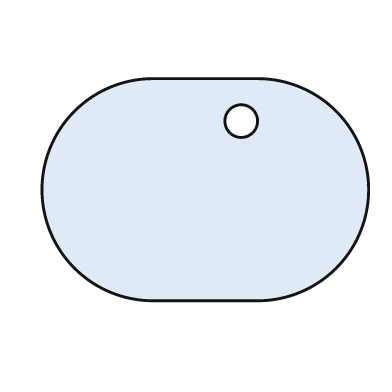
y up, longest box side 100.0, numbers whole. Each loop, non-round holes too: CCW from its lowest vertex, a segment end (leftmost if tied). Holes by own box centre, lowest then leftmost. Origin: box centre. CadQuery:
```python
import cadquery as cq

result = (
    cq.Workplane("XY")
    .moveTo(-16.0, -34.0)
    .lineTo(16.0, -34.0)
    .threePointArc((50.0, 0.0), (16.0, 34.0))
    .lineTo(-16.0, 34.0)
    .threePointArc((-50.0, 0.0), (-16.0, -34.0))
    .close()
    .moveTo(11.0, 21.0)
    .circle(5.0)
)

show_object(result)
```